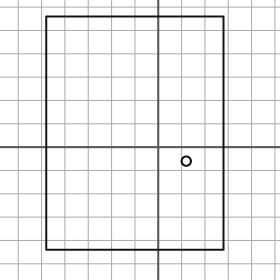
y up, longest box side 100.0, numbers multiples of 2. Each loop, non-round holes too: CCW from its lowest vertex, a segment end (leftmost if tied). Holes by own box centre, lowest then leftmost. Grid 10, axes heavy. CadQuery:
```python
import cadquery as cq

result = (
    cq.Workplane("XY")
    .moveTo(-48.0, -44.0)
    .lineTo(28.0, -44.0)
    .lineTo(28.0, 56.0)
    .lineTo(-48.0, 56.0)
    .close()
    .moveTo(12.0, -6.0)
    .circle(2.0)
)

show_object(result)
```